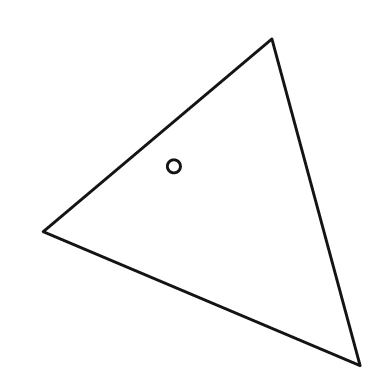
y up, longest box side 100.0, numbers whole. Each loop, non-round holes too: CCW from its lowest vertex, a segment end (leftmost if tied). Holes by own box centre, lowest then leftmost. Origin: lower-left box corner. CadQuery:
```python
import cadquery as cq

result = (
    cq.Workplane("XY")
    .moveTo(97.0, 0.0)
    .lineTo(70.0, 100.0)
    .lineTo(0.0, 41.0)
    .close()
    .moveTo(40.0, 61.0)
    .circle(2.0)
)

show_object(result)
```